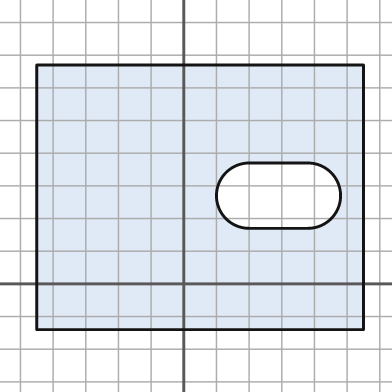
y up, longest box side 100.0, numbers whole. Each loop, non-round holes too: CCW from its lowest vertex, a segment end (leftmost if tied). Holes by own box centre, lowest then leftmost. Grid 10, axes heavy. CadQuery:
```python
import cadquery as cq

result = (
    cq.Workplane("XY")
    .moveTo(-45.0, -14.0)
    .lineTo(55.0, -14.0)
    .lineTo(55.0, 67.0)
    .lineTo(-45.0, 67.0)
    .close()
    .moveTo(20.0, 17.0)
    .lineTo(38.0, 17.0)
    .threePointArc((48.0, 27.0), (38.0, 37.0))
    .lineTo(20.0, 37.0)
    .threePointArc((10.0, 27.0), (20.0, 17.0))
    .close()
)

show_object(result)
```